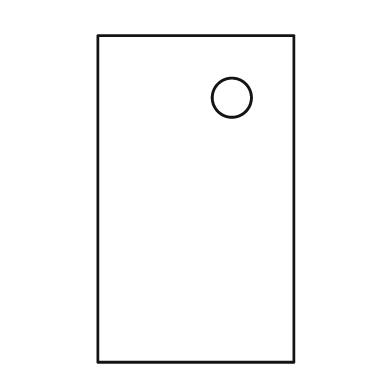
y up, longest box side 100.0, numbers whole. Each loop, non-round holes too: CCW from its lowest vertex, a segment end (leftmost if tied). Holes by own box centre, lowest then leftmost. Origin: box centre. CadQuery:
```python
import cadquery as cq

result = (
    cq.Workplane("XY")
    .moveTo(-30.0, -50.0)
    .lineTo(30.0, -50.0)
    .lineTo(30.0, 50.0)
    .lineTo(-30.0, 50.0)
    .close()
    .moveTo(11.0, 31.0)
    .circle(6.0)
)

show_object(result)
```